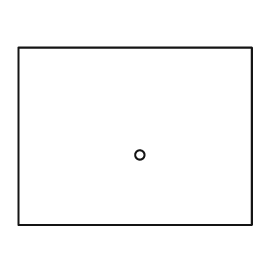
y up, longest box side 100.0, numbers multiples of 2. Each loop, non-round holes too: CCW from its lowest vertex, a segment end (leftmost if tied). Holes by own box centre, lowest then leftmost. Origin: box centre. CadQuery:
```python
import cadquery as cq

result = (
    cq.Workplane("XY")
    .moveTo(-50.0, -38.0)
    .lineTo(50.0, -38.0)
    .lineTo(50.0, 38.0)
    .lineTo(-50.0, 38.0)
    .close()
    .moveTo(2.0, -8.0)
    .circle(2.0)
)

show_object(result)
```